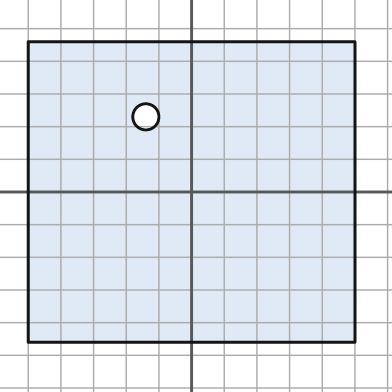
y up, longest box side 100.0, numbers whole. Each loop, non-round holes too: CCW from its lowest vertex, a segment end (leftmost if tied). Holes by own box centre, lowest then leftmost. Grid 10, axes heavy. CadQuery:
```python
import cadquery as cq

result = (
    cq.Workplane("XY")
    .moveTo(-50.0, -46.0)
    .lineTo(50.0, -46.0)
    .lineTo(50.0, 46.0)
    .lineTo(-50.0, 46.0)
    .close()
    .moveTo(-14.0, 23.0)
    .circle(4.0)
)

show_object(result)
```